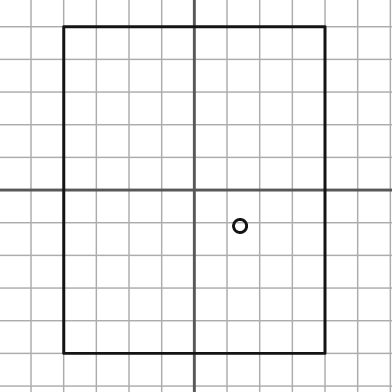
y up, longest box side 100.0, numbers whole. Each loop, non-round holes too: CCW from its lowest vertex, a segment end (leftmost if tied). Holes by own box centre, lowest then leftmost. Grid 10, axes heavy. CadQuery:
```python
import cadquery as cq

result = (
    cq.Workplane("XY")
    .moveTo(-40.0, -50.0)
    .lineTo(40.0, -50.0)
    .lineTo(40.0, 50.0)
    .lineTo(-40.0, 50.0)
    .close()
    .moveTo(14.0, -11.0)
    .circle(2.0)
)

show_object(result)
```